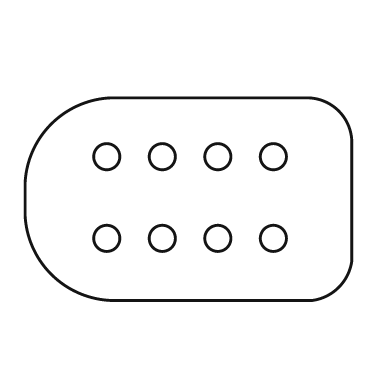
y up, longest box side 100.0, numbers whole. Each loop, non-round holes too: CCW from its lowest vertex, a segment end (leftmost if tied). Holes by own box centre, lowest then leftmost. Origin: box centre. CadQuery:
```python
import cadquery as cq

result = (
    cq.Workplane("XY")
    .moveTo(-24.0, -31.0)
    .lineTo(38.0, -31.0)
    .threePointArc((46.0, -27.0), (50.0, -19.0))
    .lineTo(50.0, 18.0)
    .threePointArc((46.0, 27.0), (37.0, 31.0))
    .lineTo(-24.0, 31.0)
    .threePointArc((-42.0, 23.0), (-50.0, 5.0))
    .lineTo(-50.0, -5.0)
    .threePointArc((-42.0, -23.0), (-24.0, -31.0))
    .close()
    .moveTo(-25.0, -12.0)
    .circle(4.0)
    .moveTo(-8.0, -12.0)
    .circle(4.0)
    .moveTo(9.0, -12.0)
    .circle(4.0)
    .moveTo(26.0, -12.0)
    .circle(4.0)
    .moveTo(-25.0, 13.0)
    .circle(4.0)
    .moveTo(-8.0, 13.0)
    .circle(4.0)
    .moveTo(9.0, 13.0)
    .circle(4.0)
    .moveTo(26.0, 13.0)
    .circle(4.0)
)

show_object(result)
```